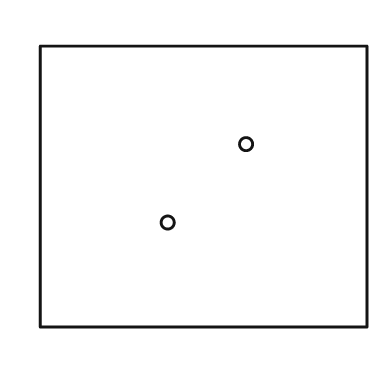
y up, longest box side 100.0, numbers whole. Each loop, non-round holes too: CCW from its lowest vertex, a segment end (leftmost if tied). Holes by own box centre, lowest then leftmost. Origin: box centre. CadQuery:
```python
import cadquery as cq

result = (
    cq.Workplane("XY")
    .moveTo(-50.0, -43.0)
    .lineTo(50.0, -43.0)
    .lineTo(50.0, 43.0)
    .lineTo(-50.0, 43.0)
    .close()
    .moveTo(-11.0, -11.0)
    .circle(2.0)
    .moveTo(13.0, 13.0)
    .circle(2.0)
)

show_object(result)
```